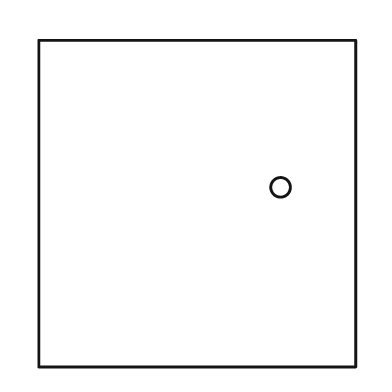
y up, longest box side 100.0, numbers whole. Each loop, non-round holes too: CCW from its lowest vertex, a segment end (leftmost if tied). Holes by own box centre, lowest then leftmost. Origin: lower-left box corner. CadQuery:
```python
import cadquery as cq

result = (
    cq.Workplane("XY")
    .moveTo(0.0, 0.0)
    .lineTo(97.0, 0.0)
    .lineTo(97.0, 100.0)
    .lineTo(0.0, 100.0)
    .close()
    .moveTo(74.0, 55.0)
    .circle(3.0)
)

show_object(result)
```